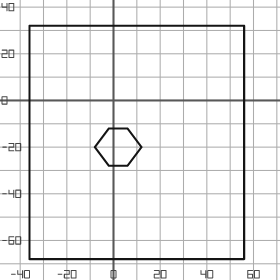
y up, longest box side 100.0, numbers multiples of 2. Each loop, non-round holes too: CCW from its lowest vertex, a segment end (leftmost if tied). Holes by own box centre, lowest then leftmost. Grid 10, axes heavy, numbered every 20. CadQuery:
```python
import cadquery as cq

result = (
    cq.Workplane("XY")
    .moveTo(-36.0, -68.0)
    .lineTo(56.0, -68.0)
    .lineTo(56.0, 32.0)
    .lineTo(-36.0, 32.0)
    .close()
    .moveTo(-2.0, -28.0)
    .lineTo(6.0, -28.0)
    .lineTo(12.0, -20.0)
    .lineTo(6.0, -12.0)
    .lineTo(-2.0, -12.0)
    .lineTo(-8.0, -20.0)
    .close()
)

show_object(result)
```